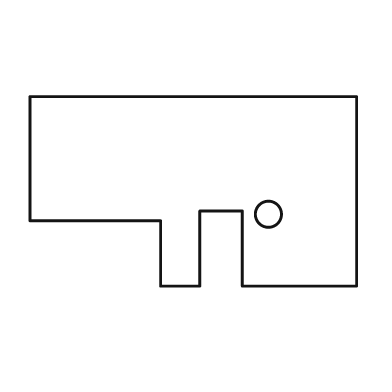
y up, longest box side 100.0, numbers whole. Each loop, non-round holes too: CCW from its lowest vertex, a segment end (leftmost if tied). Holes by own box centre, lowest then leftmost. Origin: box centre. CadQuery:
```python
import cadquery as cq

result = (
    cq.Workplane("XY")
    .moveTo(-10.0, -29.0)
    .lineTo(2.0, -29.0)
    .lineTo(2.0, -6.0)
    .lineTo(15.0, -6.0)
    .lineTo(15.0, -29.0)
    .lineTo(50.0, -29.0)
    .lineTo(50.0, 29.0)
    .lineTo(-50.0, 29.0)
    .lineTo(-50.0, -9.0)
    .lineTo(-10.0, -9.0)
    .close()
    .moveTo(23.0, -7.0)
    .circle(4.0)
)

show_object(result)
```